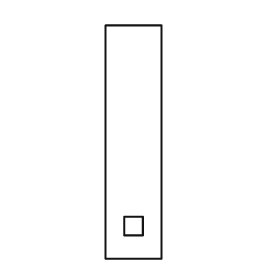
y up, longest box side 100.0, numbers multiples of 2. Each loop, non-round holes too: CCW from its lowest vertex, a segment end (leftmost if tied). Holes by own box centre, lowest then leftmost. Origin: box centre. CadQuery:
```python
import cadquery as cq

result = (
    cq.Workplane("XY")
    .moveTo(-12.0, -50.0)
    .lineTo(12.0, -50.0)
    .lineTo(12.0, 50.0)
    .lineTo(-12.0, 50.0)
    .close()
    .moveTo(-4.0, -40.0)
    .lineTo(4.0, -40.0)
    .lineTo(4.0, -32.0)
    .lineTo(-4.0, -32.0)
    .close()
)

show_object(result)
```